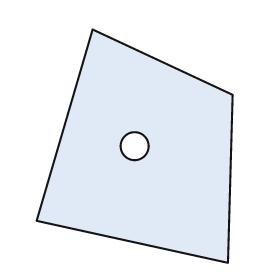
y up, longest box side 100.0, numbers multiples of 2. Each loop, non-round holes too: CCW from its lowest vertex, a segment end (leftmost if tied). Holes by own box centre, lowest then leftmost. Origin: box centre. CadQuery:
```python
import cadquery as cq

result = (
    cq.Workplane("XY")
    .moveTo(40.0, -50.0)
    .lineTo(42.0, 22.0)
    .lineTo(-18.0, 50.0)
    .lineTo(-42.0, -32.0)
    .close()
    .moveTo(0.0, 0.0)
    .circle(6.0)
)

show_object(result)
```